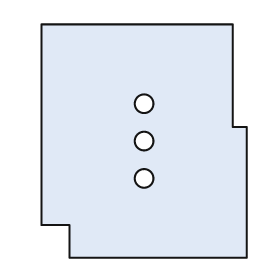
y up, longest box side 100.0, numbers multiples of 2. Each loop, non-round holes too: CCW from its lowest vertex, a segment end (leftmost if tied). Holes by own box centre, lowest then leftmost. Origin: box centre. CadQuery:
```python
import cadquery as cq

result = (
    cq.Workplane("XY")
    .moveTo(-32.0, -50.0)
    .lineTo(44.0, -50.0)
    .lineTo(44.0, 6.0)
    .lineTo(38.0, 6.0)
    .lineTo(38.0, 50.0)
    .lineTo(-44.0, 50.0)
    .lineTo(-44.0, -36.0)
    .lineTo(-32.0, -36.0)
    .close()
    .moveTo(0.0, -16.0)
    .circle(4.0)
    .moveTo(0.0, 0.0)
    .circle(4.0)
    .moveTo(0.0, 16.0)
    .circle(4.0)
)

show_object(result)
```